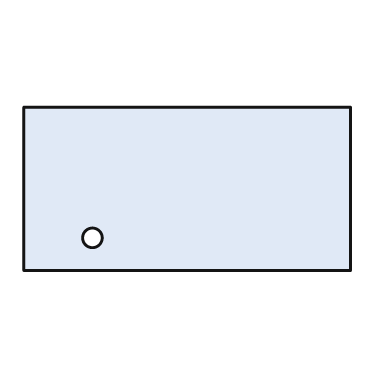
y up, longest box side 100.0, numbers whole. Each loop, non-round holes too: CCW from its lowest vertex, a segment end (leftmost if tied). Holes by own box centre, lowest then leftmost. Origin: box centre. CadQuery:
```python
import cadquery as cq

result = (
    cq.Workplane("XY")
    .moveTo(-50.0, -25.0)
    .lineTo(50.0, -25.0)
    .lineTo(50.0, 25.0)
    .lineTo(-50.0, 25.0)
    .close()
    .moveTo(-29.0, -15.0)
    .circle(3.0)
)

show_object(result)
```